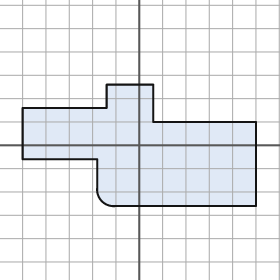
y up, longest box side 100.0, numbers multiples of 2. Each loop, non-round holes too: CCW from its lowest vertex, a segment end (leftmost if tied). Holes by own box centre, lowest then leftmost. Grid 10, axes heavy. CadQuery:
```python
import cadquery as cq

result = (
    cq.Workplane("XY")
    .moveTo(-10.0, -26.0)
    .lineTo(50.0, -26.0)
    .lineTo(50.0, 10.0)
    .lineTo(6.0, 10.0)
    .lineTo(6.0, 26.0)
    .lineTo(-14.0, 26.0)
    .lineTo(-14.0, 16.0)
    .lineTo(-50.0, 16.0)
    .lineTo(-50.0, -6.0)
    .lineTo(-18.0, -6.0)
    .lineTo(-18.0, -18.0)
    .threePointArc((-16.0, -24.0), (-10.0, -26.0))
    .close()
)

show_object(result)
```